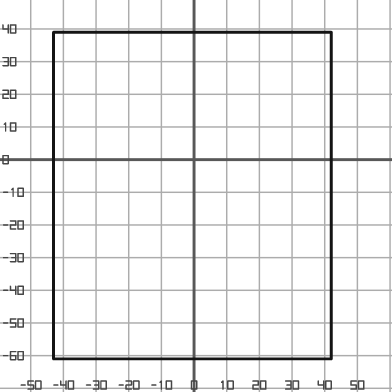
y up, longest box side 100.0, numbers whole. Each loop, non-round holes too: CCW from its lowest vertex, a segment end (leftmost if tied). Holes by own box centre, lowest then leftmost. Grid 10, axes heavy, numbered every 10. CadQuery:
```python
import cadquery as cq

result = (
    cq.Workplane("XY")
    .moveTo(-43.0, -61.0)
    .lineTo(42.0, -61.0)
    .lineTo(42.0, 39.0)
    .lineTo(-43.0, 39.0)
    .close()
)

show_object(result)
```